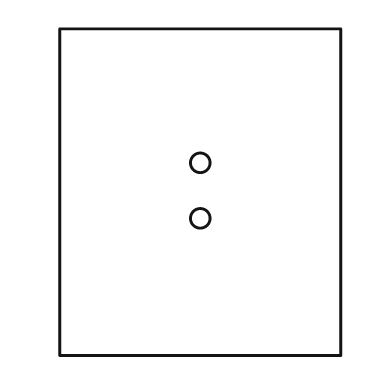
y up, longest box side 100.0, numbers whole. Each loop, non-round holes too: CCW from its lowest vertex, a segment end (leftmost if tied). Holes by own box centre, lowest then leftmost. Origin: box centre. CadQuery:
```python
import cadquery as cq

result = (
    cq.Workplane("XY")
    .moveTo(-43.0, -50.0)
    .lineTo(43.0, -50.0)
    .lineTo(43.0, 50.0)
    .lineTo(-43.0, 50.0)
    .close()
    .moveTo(0.0, -8.0)
    .circle(3.0)
    .moveTo(0.0, 9.0)
    .circle(3.0)
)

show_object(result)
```